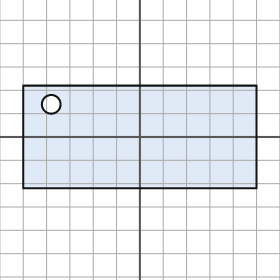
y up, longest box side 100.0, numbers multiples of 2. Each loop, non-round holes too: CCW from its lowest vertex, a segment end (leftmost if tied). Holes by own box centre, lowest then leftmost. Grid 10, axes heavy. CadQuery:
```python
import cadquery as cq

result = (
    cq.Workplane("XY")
    .moveTo(-50.0, -22.0)
    .lineTo(50.0, -22.0)
    .lineTo(50.0, 22.0)
    .lineTo(-50.0, 22.0)
    .close()
    .moveTo(-38.0, 14.0)
    .circle(4.0)
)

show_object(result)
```